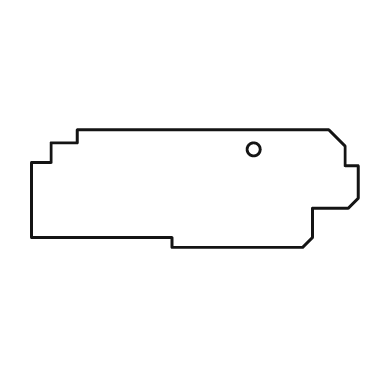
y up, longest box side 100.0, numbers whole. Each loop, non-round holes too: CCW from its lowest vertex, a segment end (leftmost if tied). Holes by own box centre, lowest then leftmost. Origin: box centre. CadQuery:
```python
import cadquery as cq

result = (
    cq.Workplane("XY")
    .moveTo(-7.0, -18.0)
    .lineTo(33.0, -18.0)
    .lineTo(36.0, -15.0)
    .lineTo(36.0, -6.0)
    .lineTo(47.0, -6.0)
    .lineTo(50.0, -3.0)
    .lineTo(50.0, 7.0)
    .lineTo(46.0, 7.0)
    .lineTo(46.0, 13.0)
    .lineTo(41.0, 18.0)
    .lineTo(-36.0, 18.0)
    .lineTo(-36.0, 14.0)
    .lineTo(-44.0, 14.0)
    .lineTo(-44.0, 8.0)
    .lineTo(-50.0, 8.0)
    .lineTo(-50.0, -15.0)
    .lineTo(-7.0, -15.0)
    .close()
    .moveTo(18.0, 12.0)
    .circle(2.0)
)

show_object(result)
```